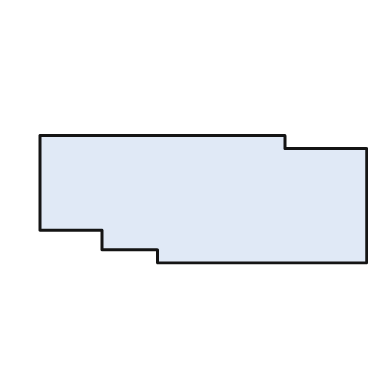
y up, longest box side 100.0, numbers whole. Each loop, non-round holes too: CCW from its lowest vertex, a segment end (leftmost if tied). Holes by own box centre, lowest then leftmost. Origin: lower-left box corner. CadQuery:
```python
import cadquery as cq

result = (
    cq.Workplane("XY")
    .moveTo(36.0, 0.0)
    .lineTo(100.0, 0.0)
    .lineTo(100.0, 35.0)
    .lineTo(75.0, 35.0)
    .lineTo(75.0, 39.0)
    .lineTo(0.0, 39.0)
    .lineTo(0.0, 10.0)
    .lineTo(19.0, 10.0)
    .lineTo(19.0, 4.0)
    .lineTo(36.0, 4.0)
    .close()
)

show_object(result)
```